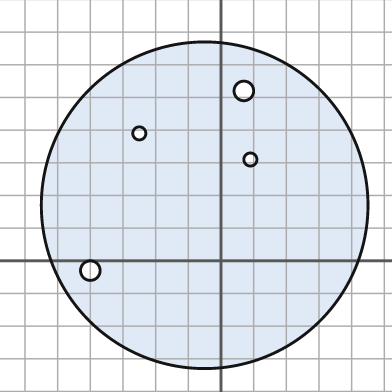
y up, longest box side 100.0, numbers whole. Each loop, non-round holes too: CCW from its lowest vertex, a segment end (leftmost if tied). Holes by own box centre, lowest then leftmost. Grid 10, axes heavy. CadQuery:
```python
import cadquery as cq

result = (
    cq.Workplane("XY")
    .moveTo(-5.0, 17.0)
    .circle(50.0)
    .moveTo(-40.0, -3.0)
    .circle(3.0)
    .moveTo(9.0, 31.0)
    .circle(2.0)
    .moveTo(-25.0, 39.0)
    .circle(2.0)
    .moveTo(7.0, 52.0)
    .circle(3.0)
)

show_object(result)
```